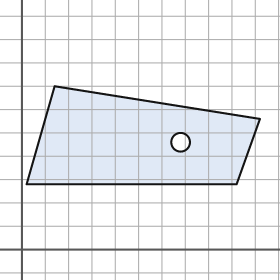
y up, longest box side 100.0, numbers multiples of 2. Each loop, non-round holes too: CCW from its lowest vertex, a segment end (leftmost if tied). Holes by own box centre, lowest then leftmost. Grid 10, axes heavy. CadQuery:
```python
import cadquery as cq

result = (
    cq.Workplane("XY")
    .moveTo(2.0, 28.0)
    .lineTo(92.0, 28.0)
    .lineTo(102.0, 56.0)
    .lineTo(14.0, 70.0)
    .close()
    .moveTo(68.0, 46.0)
    .circle(4.0)
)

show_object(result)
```